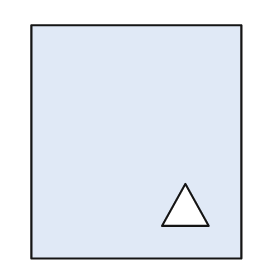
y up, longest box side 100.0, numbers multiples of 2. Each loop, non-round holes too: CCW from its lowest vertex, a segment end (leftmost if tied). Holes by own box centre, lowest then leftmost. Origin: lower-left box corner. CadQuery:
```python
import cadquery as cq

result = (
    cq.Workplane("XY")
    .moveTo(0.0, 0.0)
    .lineTo(90.0, 0.0)
    .lineTo(90.0, 100.0)
    .lineTo(0.0, 100.0)
    .close()
    .moveTo(56.0, 14.0)
    .lineTo(76.0, 14.0)
    .lineTo(66.0, 32.0)
    .close()
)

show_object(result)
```